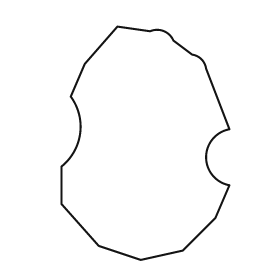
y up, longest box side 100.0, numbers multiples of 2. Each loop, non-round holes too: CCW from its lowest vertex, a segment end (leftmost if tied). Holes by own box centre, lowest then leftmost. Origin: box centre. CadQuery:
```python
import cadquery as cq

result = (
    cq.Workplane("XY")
    .moveTo(-2.0, -50.0)
    .lineTo(16.0, -46.0)
    .lineTo(30.0, -32.0)
    .lineTo(36.0, -18.0)
    .threePointArc((26.0, -6.0), (36.0, 6.0))
    .lineTo(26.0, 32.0)
    .threePointArc((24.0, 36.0), (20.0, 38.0))
    .lineTo(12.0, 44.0)
    .threePointArc((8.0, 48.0), (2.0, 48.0))
    .lineTo(-12.0, 50.0)
    .lineTo(-26.0, 34.0)
    .lineTo(-32.0, 20.0)
    .threePointArc((-28.0, 4.0), (-36.0, -10.0))
    .lineTo(-36.0, -26.0)
    .lineTo(-20.0, -44.0)
    .close()
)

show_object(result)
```